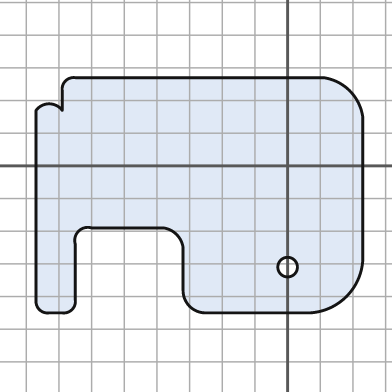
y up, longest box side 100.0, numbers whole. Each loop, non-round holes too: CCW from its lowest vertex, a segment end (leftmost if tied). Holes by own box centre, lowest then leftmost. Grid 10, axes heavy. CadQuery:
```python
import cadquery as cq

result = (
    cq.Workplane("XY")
    .moveTo(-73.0, -45.0)
    .lineTo(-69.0, -45.0)
    .threePointArc((-66.0, -44.0), (-65.0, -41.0))
    .lineTo(-65.0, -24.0)
    .threePointArc((-64.0, -20.0), (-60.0, -19.0))
    .lineTo(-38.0, -19.0)
    .threePointArc((-34.0, -21.0), (-32.0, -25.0))
    .lineTo(-32.0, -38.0)
    .threePointArc((-30.0, -43.0), (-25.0, -45.0))
    .lineTo(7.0, -45.0)
    .threePointArc((18.0, -40.0), (23.0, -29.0))
    .lineTo(23.0, 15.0)
    .threePointArc((19.0, 23.0), (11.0, 27.0))
    .lineTo(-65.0, 27.0)
    .threePointArc((-68.0, 26.0), (-69.0, 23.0))
    .lineTo(-69.0, 17.0)
    .threePointArc((-73.0, 19.0), (-77.0, 17.0))
    .lineTo(-77.0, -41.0)
    .threePointArc((-76.0, -44.0), (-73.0, -45.0))
    .close()
    .moveTo(0.0, -31.0)
    .circle(3.0)
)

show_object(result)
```